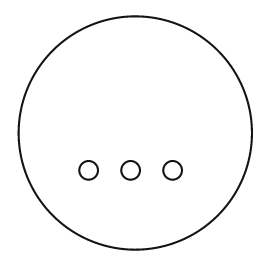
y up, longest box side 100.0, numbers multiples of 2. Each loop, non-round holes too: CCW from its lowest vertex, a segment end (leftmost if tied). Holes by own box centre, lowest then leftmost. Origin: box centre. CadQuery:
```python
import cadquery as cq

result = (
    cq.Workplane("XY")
    .moveTo(0.0, 0.0)
    .circle(50.0)
    .moveTo(-20.0, -16.0)
    .circle(4.0)
    .moveTo(-2.0, -16.0)
    .circle(4.0)
    .moveTo(16.0, -16.0)
    .circle(4.0)
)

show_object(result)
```